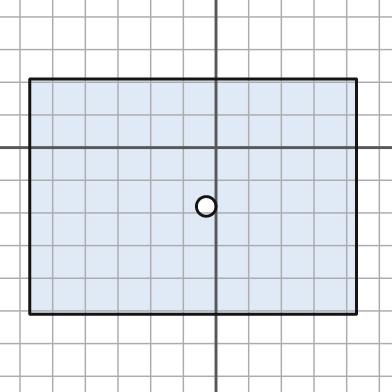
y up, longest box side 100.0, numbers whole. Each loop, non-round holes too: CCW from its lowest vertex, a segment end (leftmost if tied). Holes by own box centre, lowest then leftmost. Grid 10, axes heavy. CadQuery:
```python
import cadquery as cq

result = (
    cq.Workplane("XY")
    .moveTo(-57.0, -51.0)
    .lineTo(43.0, -51.0)
    .lineTo(43.0, 21.0)
    .lineTo(-57.0, 21.0)
    .close()
    .moveTo(-3.0, -18.0)
    .circle(3.0)
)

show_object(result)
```